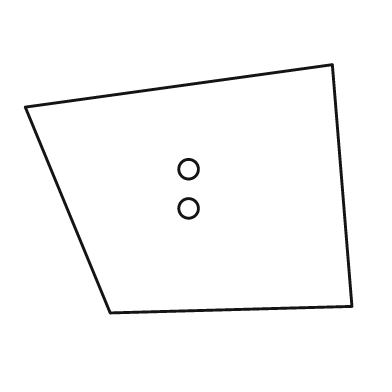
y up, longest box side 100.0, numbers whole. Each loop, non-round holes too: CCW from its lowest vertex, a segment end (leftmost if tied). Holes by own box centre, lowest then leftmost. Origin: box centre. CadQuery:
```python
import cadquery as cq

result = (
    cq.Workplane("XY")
    .moveTo(-24.0, -38.0)
    .lineTo(50.0, -36.0)
    .lineTo(44.0, 38.0)
    .lineTo(-50.0, 25.0)
    .close()
    .moveTo(0.0, -6.0)
    .circle(3.0)
    .moveTo(0.0, 6.0)
    .circle(3.0)
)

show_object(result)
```